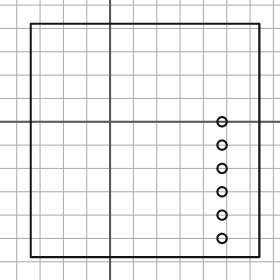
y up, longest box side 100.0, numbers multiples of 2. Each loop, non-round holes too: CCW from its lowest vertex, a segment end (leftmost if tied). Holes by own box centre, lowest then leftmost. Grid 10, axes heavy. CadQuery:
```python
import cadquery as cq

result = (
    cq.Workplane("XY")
    .moveTo(-34.0, -58.0)
    .lineTo(64.0, -58.0)
    .lineTo(64.0, 42.0)
    .lineTo(-34.0, 42.0)
    .close()
    .moveTo(48.0, -50.0)
    .circle(2.0)
    .moveTo(48.0, -40.0)
    .circle(2.0)
    .moveTo(48.0, -30.0)
    .circle(2.0)
    .moveTo(48.0, -20.0)
    .circle(2.0)
    .moveTo(48.0, -10.0)
    .circle(2.0)
    .moveTo(48.0, 0.0)
    .circle(2.0)
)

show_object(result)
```